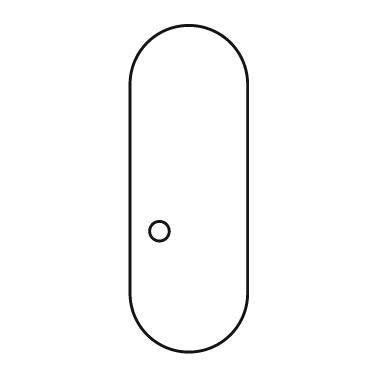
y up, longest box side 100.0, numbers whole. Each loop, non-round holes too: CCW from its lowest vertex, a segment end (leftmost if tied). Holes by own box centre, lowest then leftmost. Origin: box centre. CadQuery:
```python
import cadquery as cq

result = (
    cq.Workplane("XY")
    .moveTo(-18.0, -32.0)
    .threePointArc((0.0, -50.0), (18.0, -32.0))
    .lineTo(18.0, 32.0)
    .threePointArc((0.0, 50.0), (-18.0, 32.0))
    .close()
    .moveTo(-9.0, -13.0)
    .circle(3.0)
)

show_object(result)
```